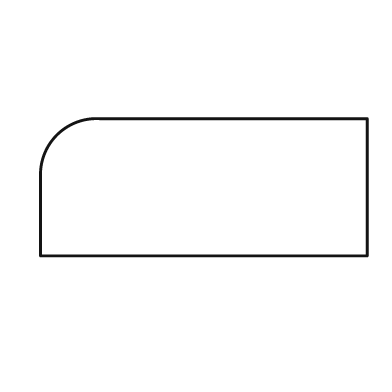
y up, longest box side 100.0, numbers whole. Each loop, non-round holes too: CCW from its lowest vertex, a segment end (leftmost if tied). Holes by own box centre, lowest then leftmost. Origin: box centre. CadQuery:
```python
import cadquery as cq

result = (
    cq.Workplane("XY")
    .moveTo(-50.0, -21.0)
    .lineTo(50.0, -21.0)
    .lineTo(50.0, 21.0)
    .lineTo(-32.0, 21.0)
    .threePointArc((-45.0, 16.0), (-50.0, 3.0))
    .close()
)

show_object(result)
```